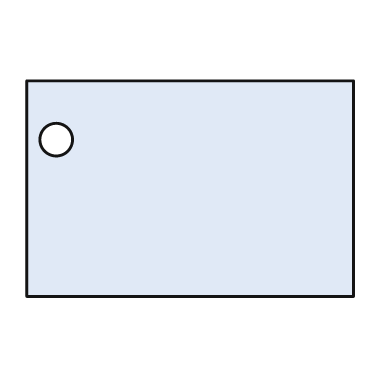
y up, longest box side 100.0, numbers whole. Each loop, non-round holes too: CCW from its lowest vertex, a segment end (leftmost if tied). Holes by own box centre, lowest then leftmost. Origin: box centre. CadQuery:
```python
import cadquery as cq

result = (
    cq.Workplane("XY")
    .moveTo(-50.0, -33.0)
    .lineTo(50.0, -33.0)
    .lineTo(50.0, 33.0)
    .lineTo(-50.0, 33.0)
    .close()
    .moveTo(-41.0, 15.0)
    .circle(5.0)
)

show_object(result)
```